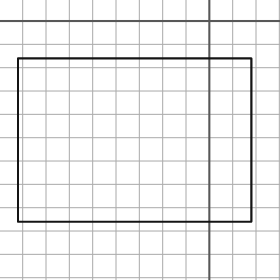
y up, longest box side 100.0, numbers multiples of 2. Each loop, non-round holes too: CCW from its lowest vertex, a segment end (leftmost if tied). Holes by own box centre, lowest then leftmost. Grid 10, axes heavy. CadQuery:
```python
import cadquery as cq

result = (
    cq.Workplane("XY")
    .moveTo(-82.0, -86.0)
    .lineTo(18.0, -86.0)
    .lineTo(18.0, -16.0)
    .lineTo(-82.0, -16.0)
    .close()
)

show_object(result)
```